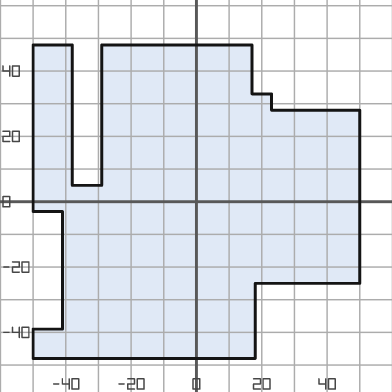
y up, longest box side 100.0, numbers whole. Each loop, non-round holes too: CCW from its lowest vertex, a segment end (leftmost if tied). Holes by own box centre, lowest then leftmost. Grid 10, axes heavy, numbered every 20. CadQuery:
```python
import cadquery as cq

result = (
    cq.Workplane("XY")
    .moveTo(-50.0, -48.0)
    .lineTo(18.0, -48.0)
    .lineTo(18.0, -25.0)
    .lineTo(50.0, -25.0)
    .lineTo(50.0, 28.0)
    .lineTo(23.0, 28.0)
    .lineTo(23.0, 33.0)
    .lineTo(17.0, 33.0)
    .lineTo(17.0, 48.0)
    .lineTo(-29.0, 48.0)
    .lineTo(-29.0, 5.0)
    .lineTo(-38.0, 5.0)
    .lineTo(-38.0, 48.0)
    .lineTo(-50.0, 48.0)
    .lineTo(-50.0, -3.0)
    .lineTo(-41.0, -3.0)
    .lineTo(-41.0, -39.0)
    .lineTo(-50.0, -39.0)
    .close()
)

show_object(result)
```